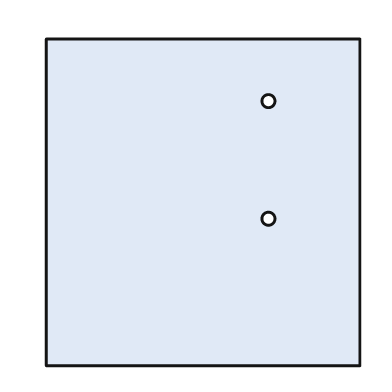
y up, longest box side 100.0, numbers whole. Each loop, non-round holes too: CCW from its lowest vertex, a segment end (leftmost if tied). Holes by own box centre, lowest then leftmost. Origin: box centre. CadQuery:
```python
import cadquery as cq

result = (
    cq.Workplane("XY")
    .moveTo(-48.0, -50.0)
    .lineTo(48.0, -50.0)
    .lineTo(48.0, 50.0)
    .lineTo(-48.0, 50.0)
    .close()
    .moveTo(20.0, -5.0)
    .circle(2.0)
    .moveTo(20.0, 31.0)
    .circle(2.0)
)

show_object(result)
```